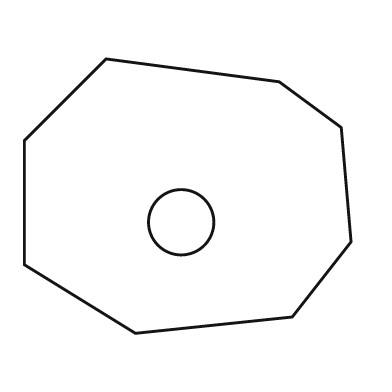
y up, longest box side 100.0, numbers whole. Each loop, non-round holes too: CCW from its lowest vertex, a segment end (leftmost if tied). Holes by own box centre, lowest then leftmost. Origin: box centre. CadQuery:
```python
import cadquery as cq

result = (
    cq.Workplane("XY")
    .moveTo(-16.0, -42.0)
    .lineTo(32.0, -37.0)
    .lineTo(50.0, -14.0)
    .lineTo(47.0, 21.0)
    .lineTo(28.0, 35.0)
    .lineTo(-25.0, 42.0)
    .lineTo(-50.0, 17.0)
    .lineTo(-50.0, -21.0)
    .close()
    .moveTo(-2.0, -8.0)
    .circle(10.0)
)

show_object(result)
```